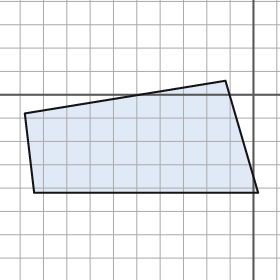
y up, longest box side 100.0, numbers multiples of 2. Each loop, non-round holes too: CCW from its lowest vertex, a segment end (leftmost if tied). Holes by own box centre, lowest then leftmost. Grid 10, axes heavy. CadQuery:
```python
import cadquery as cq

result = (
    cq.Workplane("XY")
    .moveTo(-94.0, -42.0)
    .lineTo(2.0, -42.0)
    .lineTo(-12.0, 6.0)
    .lineTo(-98.0, -8.0)
    .close()
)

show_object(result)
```